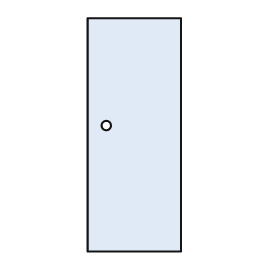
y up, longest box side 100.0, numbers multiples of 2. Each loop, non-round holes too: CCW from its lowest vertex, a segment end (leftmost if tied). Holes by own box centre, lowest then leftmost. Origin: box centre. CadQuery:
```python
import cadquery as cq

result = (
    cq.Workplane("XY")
    .moveTo(-20.0, -50.0)
    .lineTo(20.0, -50.0)
    .lineTo(20.0, 50.0)
    .lineTo(-20.0, 50.0)
    .close()
    .moveTo(-12.0, 4.0)
    .circle(2.0)
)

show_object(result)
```